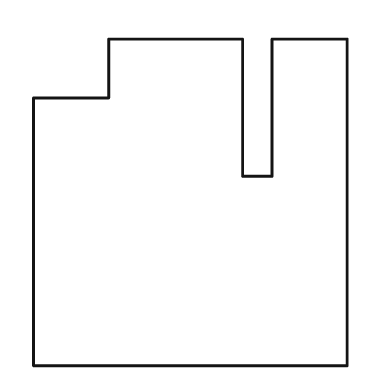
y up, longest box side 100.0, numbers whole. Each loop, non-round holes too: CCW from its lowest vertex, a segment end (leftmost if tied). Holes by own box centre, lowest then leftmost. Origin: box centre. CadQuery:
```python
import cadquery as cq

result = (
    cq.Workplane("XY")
    .moveTo(-48.0, -50.0)
    .lineTo(48.0, -50.0)
    .lineTo(48.0, 50.0)
    .lineTo(25.0, 50.0)
    .lineTo(25.0, 8.0)
    .lineTo(16.0, 8.0)
    .lineTo(16.0, 50.0)
    .lineTo(-25.0, 50.0)
    .lineTo(-25.0, 32.0)
    .lineTo(-48.0, 32.0)
    .close()
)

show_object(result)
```